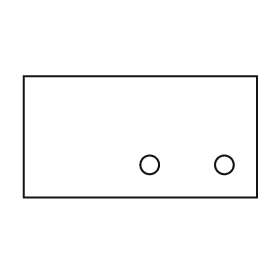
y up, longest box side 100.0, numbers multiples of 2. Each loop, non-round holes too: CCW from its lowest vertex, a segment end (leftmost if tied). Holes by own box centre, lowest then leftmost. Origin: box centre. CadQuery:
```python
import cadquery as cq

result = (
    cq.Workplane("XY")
    .moveTo(-50.0, -26.0)
    .lineTo(50.0, -26.0)
    .lineTo(50.0, 26.0)
    .lineTo(-50.0, 26.0)
    .close()
    .moveTo(4.0, -12.0)
    .circle(4.0)
    .moveTo(36.0, -12.0)
    .circle(4.0)
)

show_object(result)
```